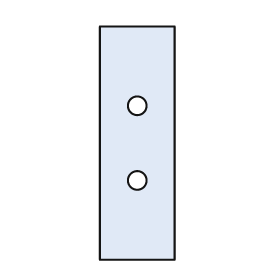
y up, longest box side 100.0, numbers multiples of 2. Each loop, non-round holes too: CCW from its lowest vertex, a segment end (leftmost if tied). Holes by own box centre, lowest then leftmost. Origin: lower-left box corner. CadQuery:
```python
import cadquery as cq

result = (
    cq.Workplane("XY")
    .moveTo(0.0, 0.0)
    .lineTo(32.0, 0.0)
    .lineTo(32.0, 100.0)
    .lineTo(0.0, 100.0)
    .close()
    .moveTo(16.0, 34.0)
    .circle(4.0)
    .moveTo(16.0, 66.0)
    .circle(4.0)
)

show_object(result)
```